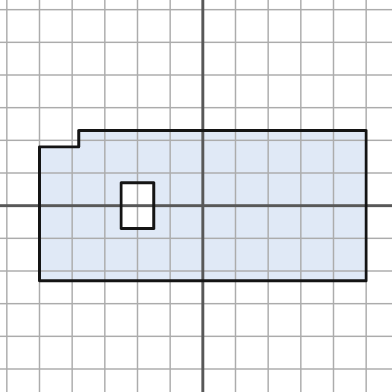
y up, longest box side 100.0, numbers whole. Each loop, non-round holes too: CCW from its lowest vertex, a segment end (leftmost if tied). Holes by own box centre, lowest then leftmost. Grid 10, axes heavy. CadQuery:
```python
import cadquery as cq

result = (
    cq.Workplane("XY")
    .moveTo(-50.0, -23.0)
    .lineTo(50.0, -23.0)
    .lineTo(50.0, 23.0)
    .lineTo(-38.0, 23.0)
    .lineTo(-38.0, 18.0)
    .lineTo(-50.0, 18.0)
    .close()
    .moveTo(-25.0, -7.0)
    .lineTo(-15.0, -7.0)
    .lineTo(-15.0, 7.0)
    .lineTo(-25.0, 7.0)
    .close()
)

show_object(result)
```